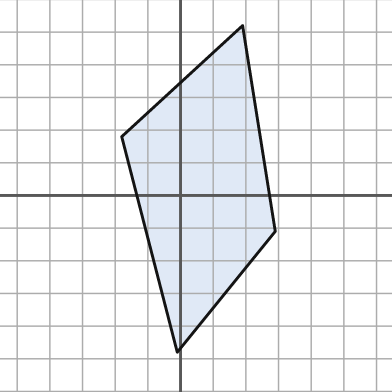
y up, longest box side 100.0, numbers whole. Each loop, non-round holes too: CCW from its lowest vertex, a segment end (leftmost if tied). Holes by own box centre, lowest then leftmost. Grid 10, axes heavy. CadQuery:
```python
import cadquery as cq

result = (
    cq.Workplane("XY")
    .moveTo(-1.0, -48.0)
    .lineTo(29.0, -11.0)
    .lineTo(19.0, 52.0)
    .lineTo(-18.0, 18.0)
    .close()
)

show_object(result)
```